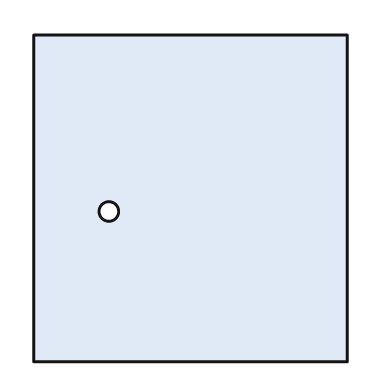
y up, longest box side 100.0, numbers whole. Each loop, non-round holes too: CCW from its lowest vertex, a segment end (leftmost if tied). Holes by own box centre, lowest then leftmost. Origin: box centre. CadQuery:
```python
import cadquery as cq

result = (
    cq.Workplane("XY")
    .moveTo(-48.0, -50.0)
    .lineTo(48.0, -50.0)
    .lineTo(48.0, 50.0)
    .lineTo(-48.0, 50.0)
    .close()
    .moveTo(-25.0, -4.0)
    .circle(3.0)
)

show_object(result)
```